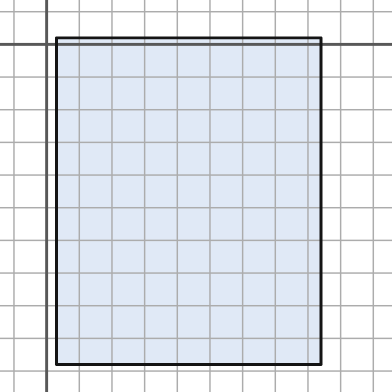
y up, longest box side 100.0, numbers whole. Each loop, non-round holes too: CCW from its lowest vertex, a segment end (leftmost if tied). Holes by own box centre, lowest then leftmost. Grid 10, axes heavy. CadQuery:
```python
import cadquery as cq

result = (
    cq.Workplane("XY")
    .moveTo(3.0, -98.0)
    .lineTo(84.0, -98.0)
    .lineTo(84.0, 2.0)
    .lineTo(3.0, 2.0)
    .close()
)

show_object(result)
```